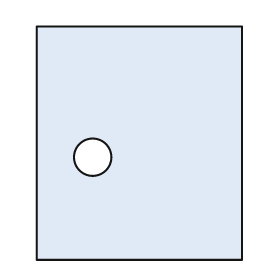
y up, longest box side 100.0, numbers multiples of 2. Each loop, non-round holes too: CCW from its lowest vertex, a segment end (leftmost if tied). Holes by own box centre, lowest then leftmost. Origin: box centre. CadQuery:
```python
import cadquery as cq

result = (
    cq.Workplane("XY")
    .moveTo(-44.0, -50.0)
    .lineTo(44.0, -50.0)
    .lineTo(44.0, 50.0)
    .lineTo(-44.0, 50.0)
    .close()
    .moveTo(-20.0, -6.0)
    .circle(8.0)
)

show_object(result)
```